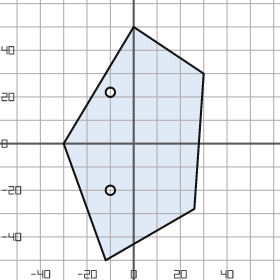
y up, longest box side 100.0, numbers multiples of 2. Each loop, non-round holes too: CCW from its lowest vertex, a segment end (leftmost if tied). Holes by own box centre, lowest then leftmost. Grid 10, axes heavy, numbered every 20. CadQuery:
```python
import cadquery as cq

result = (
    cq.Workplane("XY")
    .moveTo(-12.0, -50.0)
    .lineTo(26.0, -28.0)
    .lineTo(30.0, 30.0)
    .lineTo(0.0, 50.0)
    .lineTo(-30.0, 0.0)
    .close()
    .moveTo(-10.0, -20.0)
    .circle(2.0)
    .moveTo(-10.0, 22.0)
    .circle(2.0)
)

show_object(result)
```